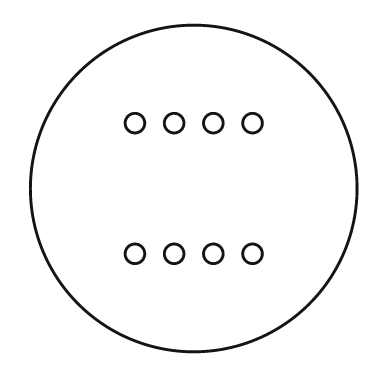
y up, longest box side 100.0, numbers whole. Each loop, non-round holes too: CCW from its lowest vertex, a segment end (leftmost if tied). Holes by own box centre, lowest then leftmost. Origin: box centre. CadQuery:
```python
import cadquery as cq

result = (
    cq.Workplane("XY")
    .moveTo(0.0, 0.0)
    .circle(50.0)
    .moveTo(-18.0, -20.0)
    .circle(3.0)
    .moveTo(-6.0, -20.0)
    .circle(3.0)
    .moveTo(6.0, -20.0)
    .circle(3.0)
    .moveTo(18.0, -20.0)
    .circle(3.0)
    .moveTo(-18.0, 20.0)
    .circle(3.0)
    .moveTo(-6.0, 20.0)
    .circle(3.0)
    .moveTo(6.0, 20.0)
    .circle(3.0)
    .moveTo(18.0, 20.0)
    .circle(3.0)
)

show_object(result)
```